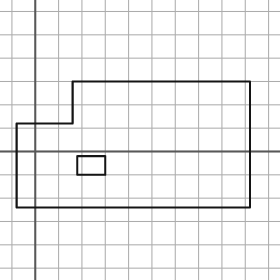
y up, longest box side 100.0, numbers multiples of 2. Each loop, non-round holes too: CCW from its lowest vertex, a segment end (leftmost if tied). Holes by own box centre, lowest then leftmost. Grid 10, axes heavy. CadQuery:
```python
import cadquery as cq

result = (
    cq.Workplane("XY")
    .moveTo(-8.0, -24.0)
    .lineTo(92.0, -24.0)
    .lineTo(92.0, 30.0)
    .lineTo(16.0, 30.0)
    .lineTo(16.0, 12.0)
    .lineTo(-8.0, 12.0)
    .close()
    .moveTo(18.0, -10.0)
    .lineTo(30.0, -10.0)
    .lineTo(30.0, -2.0)
    .lineTo(18.0, -2.0)
    .close()
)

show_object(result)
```